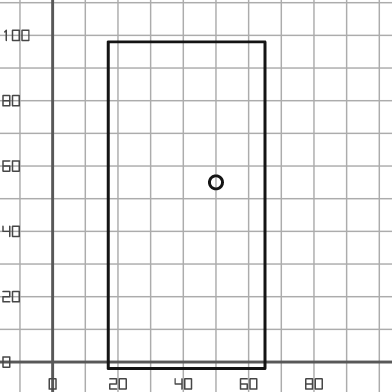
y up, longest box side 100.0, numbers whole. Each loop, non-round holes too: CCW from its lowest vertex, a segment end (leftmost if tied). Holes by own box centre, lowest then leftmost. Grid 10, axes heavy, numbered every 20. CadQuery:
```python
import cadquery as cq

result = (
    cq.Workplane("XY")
    .moveTo(17.0, -2.0)
    .lineTo(65.0, -2.0)
    .lineTo(65.0, 98.0)
    .lineTo(17.0, 98.0)
    .close()
    .moveTo(50.0, 55.0)
    .circle(2.0)
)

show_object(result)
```